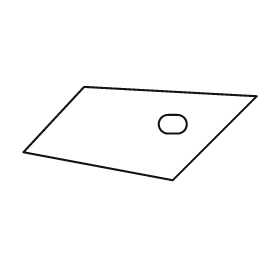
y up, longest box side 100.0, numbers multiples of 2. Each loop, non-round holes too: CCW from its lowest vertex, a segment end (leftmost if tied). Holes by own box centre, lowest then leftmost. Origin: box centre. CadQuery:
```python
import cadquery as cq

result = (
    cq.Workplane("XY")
    .moveTo(14.0, -20.0)
    .lineTo(50.0, 16.0)
    .lineTo(-24.0, 20.0)
    .lineTo(-50.0, -8.0)
    .close()
    .moveTo(12.0, 0.0)
    .lineTo(16.0, 0.0)
    .threePointArc((20.0, 4.0), (16.0, 8.0))
    .lineTo(12.0, 8.0)
    .threePointArc((8.0, 4.0), (12.0, 0.0))
    .close()
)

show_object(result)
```